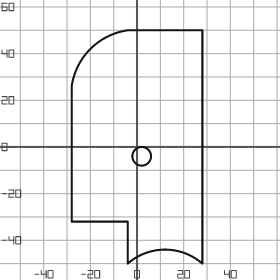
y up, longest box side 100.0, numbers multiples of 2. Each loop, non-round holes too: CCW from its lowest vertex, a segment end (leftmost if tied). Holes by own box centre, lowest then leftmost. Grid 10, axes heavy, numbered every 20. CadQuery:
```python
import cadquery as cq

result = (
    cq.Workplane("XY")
    .moveTo(-4.0, -50.0)
    .threePointArc((12.0, -44.0), (28.0, -50.0))
    .lineTo(28.0, 50.0)
    .lineTo(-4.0, 50.0)
    .threePointArc((-20.0, 42.0), (-28.0, 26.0))
    .lineTo(-28.0, -32.0)
    .lineTo(-4.0, -32.0)
    .close()
    .moveTo(2.0, -4.0)
    .circle(4.0)
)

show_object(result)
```